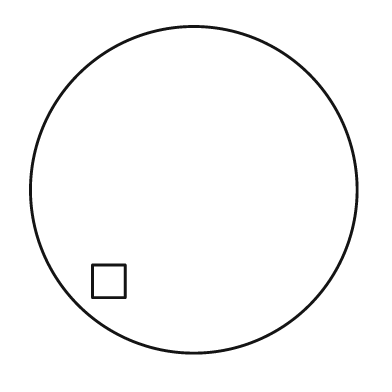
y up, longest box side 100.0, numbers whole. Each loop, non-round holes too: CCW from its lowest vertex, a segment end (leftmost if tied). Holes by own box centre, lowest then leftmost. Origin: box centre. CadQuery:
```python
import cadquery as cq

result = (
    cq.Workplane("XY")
    .moveTo(0.0, 0.0)
    .circle(50.0)
    .moveTo(-31.0, -33.0)
    .lineTo(-21.0, -33.0)
    .lineTo(-21.0, -23.0)
    .lineTo(-31.0, -23.0)
    .close()
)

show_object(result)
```